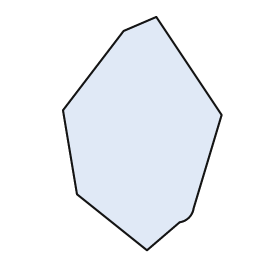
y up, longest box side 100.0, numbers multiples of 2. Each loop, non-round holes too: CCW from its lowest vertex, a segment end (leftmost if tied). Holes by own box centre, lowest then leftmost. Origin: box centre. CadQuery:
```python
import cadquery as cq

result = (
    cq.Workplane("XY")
    .moveTo(2.0, -50.0)
    .lineTo(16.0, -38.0)
    .threePointArc((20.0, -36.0), (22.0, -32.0))
    .lineTo(34.0, 8.0)
    .lineTo(6.0, 50.0)
    .lineTo(-8.0, 44.0)
    .lineTo(-34.0, 10.0)
    .lineTo(-28.0, -26.0)
    .close()
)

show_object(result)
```